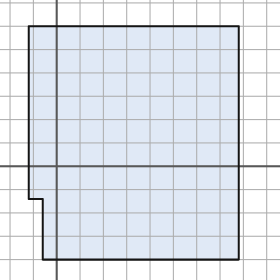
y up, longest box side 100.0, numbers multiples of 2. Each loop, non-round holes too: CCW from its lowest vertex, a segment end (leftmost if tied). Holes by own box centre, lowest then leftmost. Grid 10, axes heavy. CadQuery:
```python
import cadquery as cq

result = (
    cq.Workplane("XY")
    .moveTo(-6.0, -40.0)
    .lineTo(78.0, -40.0)
    .lineTo(78.0, 60.0)
    .lineTo(-12.0, 60.0)
    .lineTo(-12.0, -14.0)
    .lineTo(-6.0, -14.0)
    .close()
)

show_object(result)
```